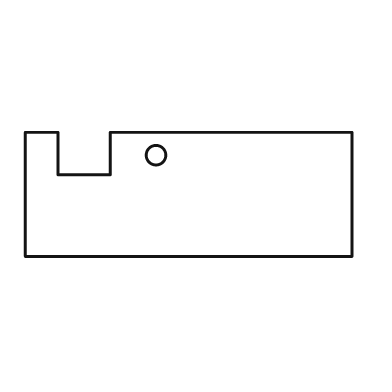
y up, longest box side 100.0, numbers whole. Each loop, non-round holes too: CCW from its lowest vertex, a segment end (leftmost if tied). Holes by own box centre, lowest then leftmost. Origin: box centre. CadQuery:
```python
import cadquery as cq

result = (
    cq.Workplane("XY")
    .moveTo(-50.0, -19.0)
    .lineTo(50.0, -19.0)
    .lineTo(50.0, 19.0)
    .lineTo(-24.0, 19.0)
    .lineTo(-24.0, 6.0)
    .lineTo(-40.0, 6.0)
    .lineTo(-40.0, 19.0)
    .lineTo(-50.0, 19.0)
    .close()
    .moveTo(-10.0, 12.0)
    .circle(3.0)
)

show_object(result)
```